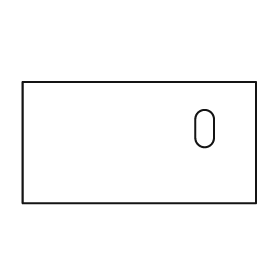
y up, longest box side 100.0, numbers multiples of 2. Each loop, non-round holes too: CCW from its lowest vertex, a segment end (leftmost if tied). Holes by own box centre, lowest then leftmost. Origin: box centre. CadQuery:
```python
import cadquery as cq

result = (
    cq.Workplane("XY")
    .moveTo(-50.0, -26.0)
    .lineTo(50.0, -26.0)
    .lineTo(50.0, 26.0)
    .lineTo(-50.0, 26.0)
    .close()
    .moveTo(24.0, 2.0)
    .threePointArc((28.0, -2.0), (32.0, 2.0))
    .lineTo(32.0, 10.0)
    .threePointArc((28.0, 14.0), (24.0, 10.0))
    .close()
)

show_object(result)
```